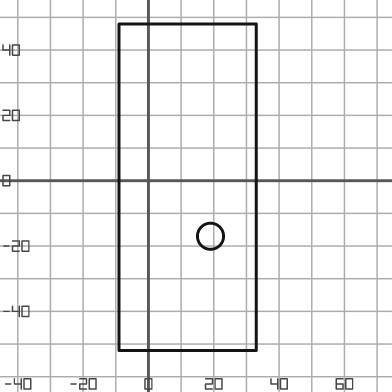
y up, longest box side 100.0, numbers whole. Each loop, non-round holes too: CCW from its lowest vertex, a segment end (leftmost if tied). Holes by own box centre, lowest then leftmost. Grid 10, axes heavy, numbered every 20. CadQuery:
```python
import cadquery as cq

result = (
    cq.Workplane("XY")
    .moveTo(-9.0, -52.0)
    .lineTo(33.0, -52.0)
    .lineTo(33.0, 48.0)
    .lineTo(-9.0, 48.0)
    .close()
    .moveTo(19.0, -17.0)
    .circle(4.0)
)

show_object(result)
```